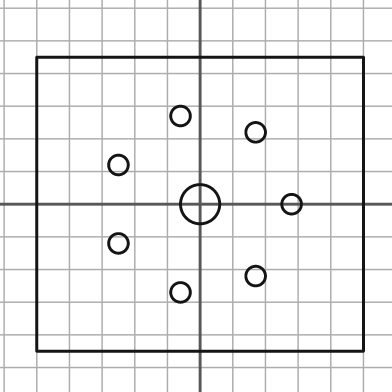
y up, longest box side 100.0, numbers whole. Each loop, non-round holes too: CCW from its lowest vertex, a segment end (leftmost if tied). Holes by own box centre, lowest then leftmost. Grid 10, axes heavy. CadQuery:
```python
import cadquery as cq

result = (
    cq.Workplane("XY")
    .moveTo(-50.0, -45.0)
    .lineTo(50.0, -45.0)
    .lineTo(50.0, 45.0)
    .lineTo(-50.0, 45.0)
    .close()
    .moveTo(-6.0, -27.0)
    .circle(3.0)
    .moveTo(17.0, -22.0)
    .circle(3.0)
    .moveTo(-25.0, -12.0)
    .circle(3.0)
    .moveTo(0.0, 0.0)
    .circle(6.0)
    .moveTo(28.0, 0.0)
    .circle(3.0)
    .moveTo(-25.0, 12.0)
    .circle(3.0)
    .moveTo(17.0, 22.0)
    .circle(3.0)
    .moveTo(-6.0, 27.0)
    .circle(3.0)
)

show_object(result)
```